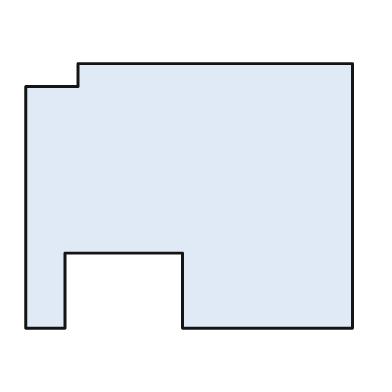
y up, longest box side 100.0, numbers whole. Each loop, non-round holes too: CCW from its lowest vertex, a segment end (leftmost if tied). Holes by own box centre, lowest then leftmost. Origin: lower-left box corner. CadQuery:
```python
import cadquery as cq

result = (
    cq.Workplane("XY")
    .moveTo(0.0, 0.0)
    .lineTo(12.0, 0.0)
    .lineTo(12.0, 23.0)
    .lineTo(48.0, 23.0)
    .lineTo(48.0, 0.0)
    .lineTo(100.0, 0.0)
    .lineTo(100.0, 81.0)
    .lineTo(16.0, 81.0)
    .lineTo(16.0, 74.0)
    .lineTo(0.0, 74.0)
    .close()
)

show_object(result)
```